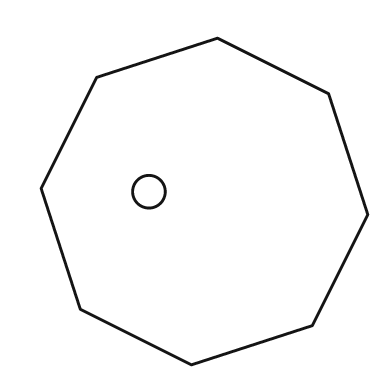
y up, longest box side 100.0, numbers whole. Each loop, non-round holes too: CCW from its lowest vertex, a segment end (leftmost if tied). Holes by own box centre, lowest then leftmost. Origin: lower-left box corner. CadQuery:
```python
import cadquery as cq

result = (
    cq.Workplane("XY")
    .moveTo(46.0, 0.0)
    .lineTo(83.0, 12.0)
    .lineTo(100.0, 46.0)
    .lineTo(88.0, 83.0)
    .lineTo(54.0, 100.0)
    .lineTo(17.0, 88.0)
    .lineTo(0.0, 54.0)
    .lineTo(12.0, 17.0)
    .close()
    .moveTo(33.0, 53.0)
    .circle(5.0)
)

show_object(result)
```